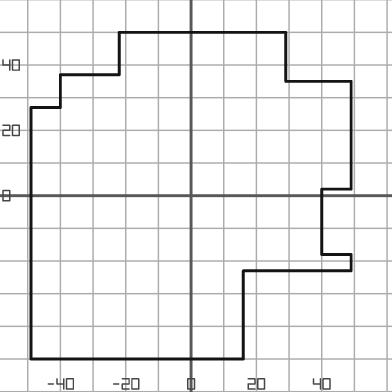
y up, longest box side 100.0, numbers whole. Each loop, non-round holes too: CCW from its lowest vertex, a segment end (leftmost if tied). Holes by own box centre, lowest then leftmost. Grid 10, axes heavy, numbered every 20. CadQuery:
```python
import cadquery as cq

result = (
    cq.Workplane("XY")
    .moveTo(-49.0, -50.0)
    .lineTo(16.0, -50.0)
    .lineTo(16.0, -23.0)
    .lineTo(49.0, -23.0)
    .lineTo(49.0, -18.0)
    .lineTo(40.0, -18.0)
    .lineTo(40.0, 2.0)
    .lineTo(49.0, 2.0)
    .lineTo(49.0, 35.0)
    .lineTo(29.0, 35.0)
    .lineTo(29.0, 50.0)
    .lineTo(-22.0, 50.0)
    .lineTo(-22.0, 37.0)
    .lineTo(-40.0, 37.0)
    .lineTo(-40.0, 27.0)
    .lineTo(-49.0, 27.0)
    .close()
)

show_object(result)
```